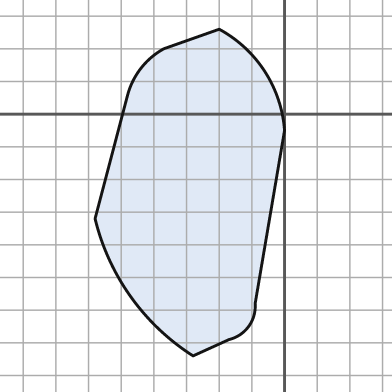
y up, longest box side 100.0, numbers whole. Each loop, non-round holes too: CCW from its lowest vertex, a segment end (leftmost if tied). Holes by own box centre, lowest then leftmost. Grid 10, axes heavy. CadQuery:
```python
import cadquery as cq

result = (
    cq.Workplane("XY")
    .moveTo(-28.0, -74.0)
    .lineTo(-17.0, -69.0)
    .threePointArc((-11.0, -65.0), (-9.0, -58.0))
    .lineTo(0.0, -5.0)
    .threePointArc((-6.0, 13.0), (-20.0, 26.0))
    .lineTo(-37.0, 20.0)
    .threePointArc((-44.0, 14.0), (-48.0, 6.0))
    .lineTo(-58.0, -32.0)
    .threePointArc((-47.0, -56.0), (-28.0, -74.0))
    .close()
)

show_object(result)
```